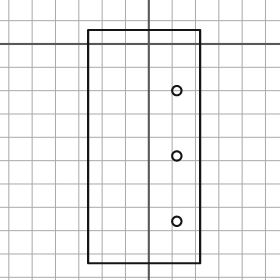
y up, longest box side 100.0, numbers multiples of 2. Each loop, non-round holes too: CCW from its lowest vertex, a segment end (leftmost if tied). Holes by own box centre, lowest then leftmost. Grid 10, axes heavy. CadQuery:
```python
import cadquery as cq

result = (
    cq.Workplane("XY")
    .moveTo(-26.0, -94.0)
    .lineTo(22.0, -94.0)
    .lineTo(22.0, 6.0)
    .lineTo(-26.0, 6.0)
    .close()
    .moveTo(12.0, -76.0)
    .circle(2.0)
    .moveTo(12.0, -48.0)
    .circle(2.0)
    .moveTo(12.0, -20.0)
    .circle(2.0)
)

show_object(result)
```